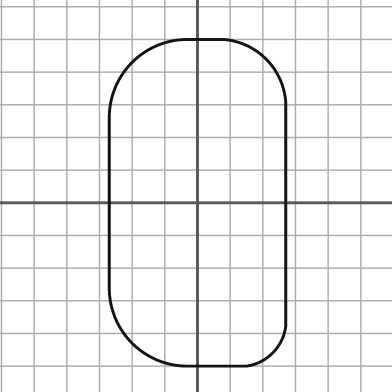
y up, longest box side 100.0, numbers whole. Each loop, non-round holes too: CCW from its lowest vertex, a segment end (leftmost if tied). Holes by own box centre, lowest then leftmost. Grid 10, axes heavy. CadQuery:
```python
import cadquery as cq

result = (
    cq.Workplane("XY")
    .moveTo(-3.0, -50.0)
    .lineTo(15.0, -50.0)
    .threePointArc((23.0, -46.0), (27.0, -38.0))
    .lineTo(27.0, 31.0)
    .threePointArc((21.0, 44.0), (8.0, 50.0))
    .lineTo(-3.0, 50.0)
    .threePointArc((-20.0, 43.0), (-27.0, 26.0))
    .lineTo(-27.0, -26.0)
    .threePointArc((-20.0, -43.0), (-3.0, -50.0))
    .close()
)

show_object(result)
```